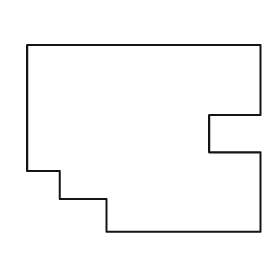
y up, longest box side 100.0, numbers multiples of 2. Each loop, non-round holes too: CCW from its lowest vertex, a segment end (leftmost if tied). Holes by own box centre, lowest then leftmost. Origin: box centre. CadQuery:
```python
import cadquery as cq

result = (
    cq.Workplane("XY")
    .moveTo(-16.0, -40.0)
    .lineTo(50.0, -40.0)
    .lineTo(50.0, -6.0)
    .lineTo(28.0, -6.0)
    .lineTo(28.0, 10.0)
    .lineTo(50.0, 10.0)
    .lineTo(50.0, 40.0)
    .lineTo(-50.0, 40.0)
    .lineTo(-50.0, -14.0)
    .lineTo(-36.0, -14.0)
    .lineTo(-36.0, -26.0)
    .lineTo(-16.0, -26.0)
    .close()
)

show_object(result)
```